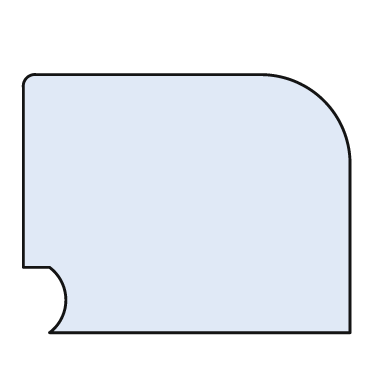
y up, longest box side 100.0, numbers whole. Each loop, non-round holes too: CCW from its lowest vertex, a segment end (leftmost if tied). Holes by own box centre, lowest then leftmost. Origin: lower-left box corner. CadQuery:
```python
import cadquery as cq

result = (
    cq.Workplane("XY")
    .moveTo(8.0, 0.0)
    .lineTo(100.0, 0.0)
    .lineTo(100.0, 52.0)
    .threePointArc((92.0, 71.0), (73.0, 79.0))
    .lineTo(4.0, 79.0)
    .threePointArc((1.0, 78.0), (0.0, 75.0))
    .lineTo(0.0, 20.0)
    .lineTo(8.0, 20.0)
    .threePointArc((13.0, 10.0), (8.0, 0.0))
    .close()
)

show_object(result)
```